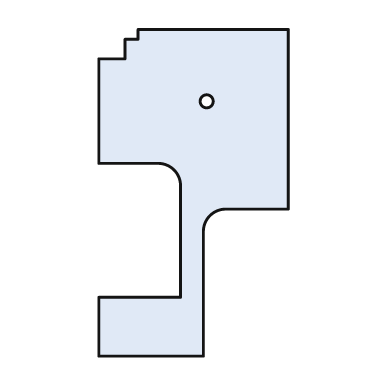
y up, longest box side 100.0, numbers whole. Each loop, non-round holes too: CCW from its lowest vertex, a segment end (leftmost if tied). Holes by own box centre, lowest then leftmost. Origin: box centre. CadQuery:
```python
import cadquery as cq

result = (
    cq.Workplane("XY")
    .moveTo(-29.0, -50.0)
    .lineTo(3.0, -50.0)
    .lineTo(3.0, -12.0)
    .threePointArc((5.0, -7.0), (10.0, -5.0))
    .lineTo(29.0, -5.0)
    .lineTo(29.0, 50.0)
    .lineTo(-17.0, 50.0)
    .lineTo(-17.0, 47.0)
    .lineTo(-21.0, 47.0)
    .lineTo(-21.0, 41.0)
    .lineTo(-29.0, 41.0)
    .lineTo(-29.0, 9.0)
    .lineTo(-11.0, 9.0)
    .threePointArc((-6.0, 7.0), (-4.0, 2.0))
    .lineTo(-4.0, -32.0)
    .lineTo(-29.0, -32.0)
    .close()
    .moveTo(4.0, 28.0)
    .circle(2.0)
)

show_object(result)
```